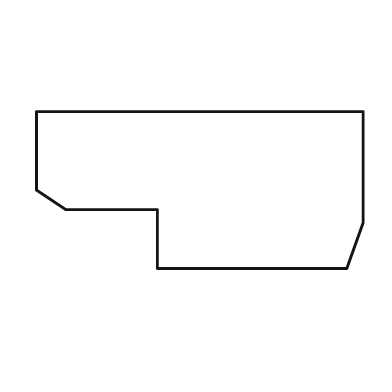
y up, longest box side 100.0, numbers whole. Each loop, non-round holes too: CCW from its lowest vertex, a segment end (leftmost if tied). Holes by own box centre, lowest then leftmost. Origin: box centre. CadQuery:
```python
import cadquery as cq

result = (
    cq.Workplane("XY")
    .moveTo(-13.0, -24.0)
    .lineTo(45.0, -24.0)
    .lineTo(50.0, -10.0)
    .lineTo(50.0, 24.0)
    .lineTo(-50.0, 24.0)
    .lineTo(-50.0, 0.0)
    .lineTo(-41.0, -6.0)
    .lineTo(-13.0, -6.0)
    .close()
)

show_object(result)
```